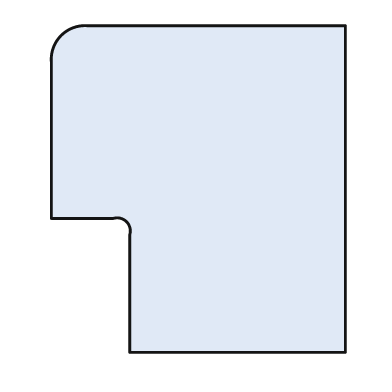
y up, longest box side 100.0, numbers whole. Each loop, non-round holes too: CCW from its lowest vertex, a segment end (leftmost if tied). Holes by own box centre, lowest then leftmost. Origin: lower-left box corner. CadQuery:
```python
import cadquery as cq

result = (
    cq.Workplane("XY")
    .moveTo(24.0, 0.0)
    .lineTo(90.0, 0.0)
    .lineTo(90.0, 100.0)
    .lineTo(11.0, 100.0)
    .threePointArc((3.0, 97.0), (0.0, 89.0))
    .lineTo(0.0, 41.0)
    .lineTo(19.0, 41.0)
    .threePointArc((23.0, 40.0), (24.0, 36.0))
    .close()
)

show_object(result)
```